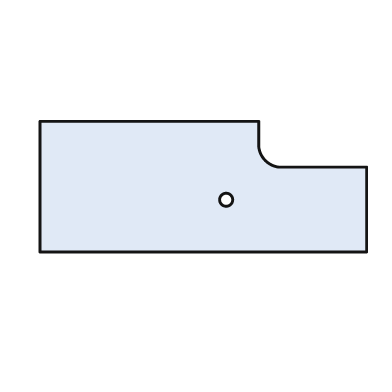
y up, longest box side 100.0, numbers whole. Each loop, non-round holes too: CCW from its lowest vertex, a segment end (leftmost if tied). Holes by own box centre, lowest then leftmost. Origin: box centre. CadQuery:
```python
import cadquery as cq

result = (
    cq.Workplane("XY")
    .moveTo(-50.0, -20.0)
    .lineTo(50.0, -20.0)
    .lineTo(50.0, 6.0)
    .lineTo(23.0, 6.0)
    .threePointArc((19.0, 8.0), (17.0, 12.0))
    .lineTo(17.0, 20.0)
    .lineTo(-50.0, 20.0)
    .close()
    .moveTo(7.0, -4.0)
    .circle(2.0)
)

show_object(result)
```